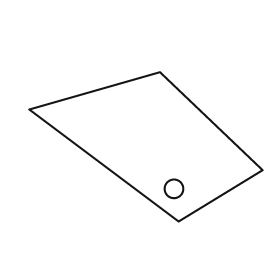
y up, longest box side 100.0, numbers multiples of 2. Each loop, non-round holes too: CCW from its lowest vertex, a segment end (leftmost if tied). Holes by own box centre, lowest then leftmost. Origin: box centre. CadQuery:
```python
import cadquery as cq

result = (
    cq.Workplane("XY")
    .moveTo(14.0, -32.0)
    .lineTo(50.0, -10.0)
    .lineTo(6.0, 32.0)
    .lineTo(-50.0, 16.0)
    .close()
    .moveTo(12.0, -18.0)
    .circle(4.0)
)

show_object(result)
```